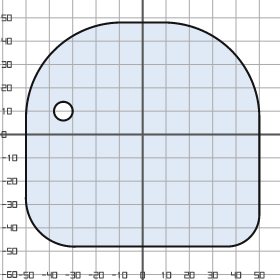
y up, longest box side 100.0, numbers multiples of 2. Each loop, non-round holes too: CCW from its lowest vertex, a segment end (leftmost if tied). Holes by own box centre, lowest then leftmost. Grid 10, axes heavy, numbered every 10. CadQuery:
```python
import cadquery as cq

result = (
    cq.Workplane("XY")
    .moveTo(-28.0, -48.0)
    .lineTo(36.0, -48.0)
    .threePointArc((46.0, -44.0), (50.0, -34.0))
    .lineTo(50.0, 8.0)
    .threePointArc((38.0, 36.0), (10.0, 48.0))
    .lineTo(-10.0, 48.0)
    .threePointArc((-38.0, 36.0), (-50.0, 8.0))
    .lineTo(-50.0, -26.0)
    .threePointArc((-44.0, -42.0), (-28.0, -48.0))
    .close()
    .moveTo(-34.0, 10.0)
    .circle(4.0)
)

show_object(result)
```